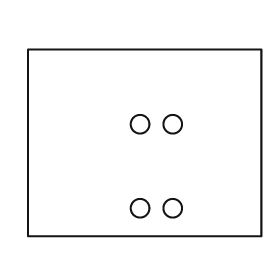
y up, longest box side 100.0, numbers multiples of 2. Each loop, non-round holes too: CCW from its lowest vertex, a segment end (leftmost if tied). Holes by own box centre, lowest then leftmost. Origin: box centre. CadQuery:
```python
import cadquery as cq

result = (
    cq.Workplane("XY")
    .moveTo(-50.0, -40.0)
    .lineTo(50.0, -40.0)
    .lineTo(50.0, 40.0)
    .lineTo(-50.0, 40.0)
    .close()
    .moveTo(-2.0, -28.0)
    .circle(4.0)
    .moveTo(12.0, -28.0)
    .circle(4.0)
    .moveTo(-2.0, 8.0)
    .circle(4.0)
    .moveTo(12.0, 8.0)
    .circle(4.0)
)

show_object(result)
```